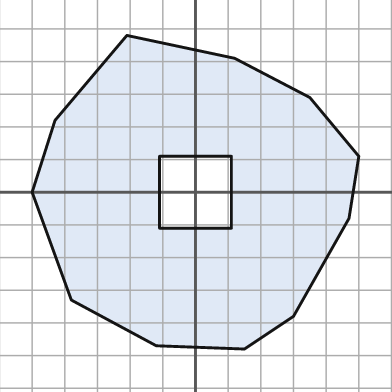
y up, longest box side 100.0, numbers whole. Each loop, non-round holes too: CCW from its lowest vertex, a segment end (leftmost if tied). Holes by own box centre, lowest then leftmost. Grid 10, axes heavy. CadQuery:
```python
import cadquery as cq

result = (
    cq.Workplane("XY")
    .moveTo(15.0, -48.0)
    .lineTo(30.0, -38.0)
    .lineTo(47.0, -8.0)
    .lineTo(50.0, 11.0)
    .lineTo(35.0, 29.0)
    .lineTo(12.0, 41.0)
    .lineTo(-21.0, 48.0)
    .lineTo(-43.0, 22.0)
    .lineTo(-50.0, 0.0)
    .lineTo(-38.0, -33.0)
    .lineTo(-12.0, -47.0)
    .close()
    .moveTo(-11.0, -11.0)
    .lineTo(11.0, -11.0)
    .lineTo(11.0, 11.0)
    .lineTo(-11.0, 11.0)
    .close()
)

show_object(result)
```